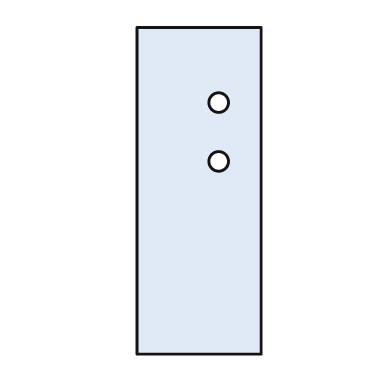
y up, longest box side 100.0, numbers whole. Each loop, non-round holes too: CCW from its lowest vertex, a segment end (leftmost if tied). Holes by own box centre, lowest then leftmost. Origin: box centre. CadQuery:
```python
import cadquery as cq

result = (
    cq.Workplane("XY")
    .moveTo(-19.0, -50.0)
    .lineTo(19.0, -50.0)
    .lineTo(19.0, 50.0)
    .lineTo(-19.0, 50.0)
    .close()
    .moveTo(6.0, 9.0)
    .circle(3.0)
    .moveTo(6.0, 27.0)
    .circle(3.0)
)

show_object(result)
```